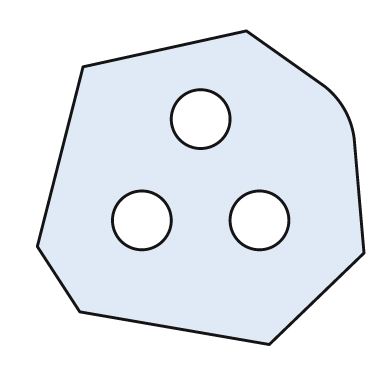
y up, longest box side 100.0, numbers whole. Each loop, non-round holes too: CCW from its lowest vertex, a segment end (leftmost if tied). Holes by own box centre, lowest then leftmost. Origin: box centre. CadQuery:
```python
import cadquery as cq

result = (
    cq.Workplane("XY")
    .moveTo(21.0, -48.0)
    .lineTo(50.0, -20.0)
    .lineTo(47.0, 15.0)
    .threePointArc((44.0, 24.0), (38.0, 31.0))
    .lineTo(14.0, 48.0)
    .lineTo(-36.0, 37.0)
    .lineTo(-50.0, -18.0)
    .lineTo(-37.0, -38.0)
    .close()
    .moveTo(-18.0, -10.0)
    .circle(9.0)
    .moveTo(18.0, -10.0)
    .circle(9.0)
    .moveTo(0.0, 21.0)
    .circle(9.0)
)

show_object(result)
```